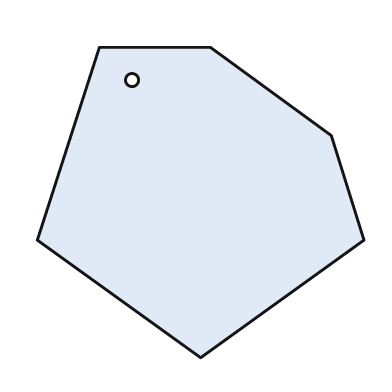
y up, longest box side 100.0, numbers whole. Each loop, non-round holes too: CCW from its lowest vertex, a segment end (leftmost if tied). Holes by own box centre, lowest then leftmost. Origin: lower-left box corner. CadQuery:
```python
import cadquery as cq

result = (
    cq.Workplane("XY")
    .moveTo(50.0, 0.0)
    .lineTo(100.0, 36.0)
    .lineTo(90.0, 68.0)
    .lineTo(53.0, 95.0)
    .lineTo(19.0, 95.0)
    .lineTo(0.0, 36.0)
    .close()
    .moveTo(29.0, 85.0)
    .circle(2.0)
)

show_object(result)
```